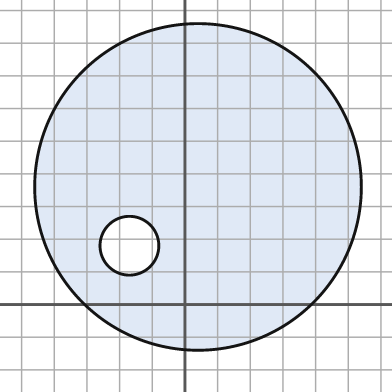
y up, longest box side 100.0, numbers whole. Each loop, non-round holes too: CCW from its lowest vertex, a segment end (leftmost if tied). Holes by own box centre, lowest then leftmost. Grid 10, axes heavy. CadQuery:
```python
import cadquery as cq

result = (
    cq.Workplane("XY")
    .moveTo(4.0, 36.0)
    .circle(50.0)
    .moveTo(-17.0, 18.0)
    .circle(9.0)
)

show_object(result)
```